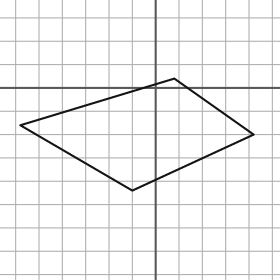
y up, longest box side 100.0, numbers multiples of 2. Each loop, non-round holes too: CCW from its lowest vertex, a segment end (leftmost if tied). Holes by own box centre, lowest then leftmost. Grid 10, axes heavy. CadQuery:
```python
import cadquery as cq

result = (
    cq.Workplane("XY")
    .moveTo(-10.0, -44.0)
    .lineTo(42.0, -20.0)
    .lineTo(8.0, 4.0)
    .lineTo(-58.0, -16.0)
    .close()
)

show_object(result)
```